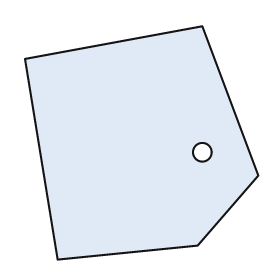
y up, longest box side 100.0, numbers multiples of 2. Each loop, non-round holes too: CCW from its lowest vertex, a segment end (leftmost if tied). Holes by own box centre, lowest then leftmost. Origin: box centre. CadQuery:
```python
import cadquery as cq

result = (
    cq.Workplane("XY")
    .moveTo(-36.0, -50.0)
    .lineTo(24.0, -44.0)
    .lineTo(50.0, -14.0)
    .lineTo(26.0, 50.0)
    .lineTo(-50.0, 36.0)
    .close()
    .moveTo(26.0, -4.0)
    .circle(4.0)
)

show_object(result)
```